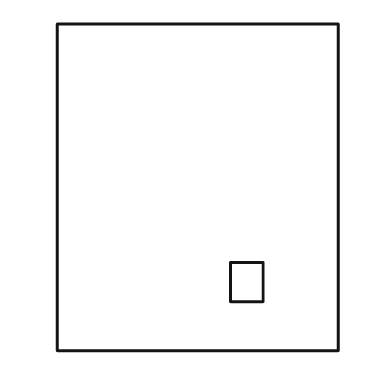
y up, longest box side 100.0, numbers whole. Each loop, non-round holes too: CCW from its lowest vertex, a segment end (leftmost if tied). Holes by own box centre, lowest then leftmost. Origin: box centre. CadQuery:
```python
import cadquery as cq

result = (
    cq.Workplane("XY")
    .moveTo(-43.0, -50.0)
    .lineTo(43.0, -50.0)
    .lineTo(43.0, 50.0)
    .lineTo(-43.0, 50.0)
    .close()
    .moveTo(10.0, -35.0)
    .lineTo(20.0, -35.0)
    .lineTo(20.0, -23.0)
    .lineTo(10.0, -23.0)
    .close()
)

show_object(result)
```